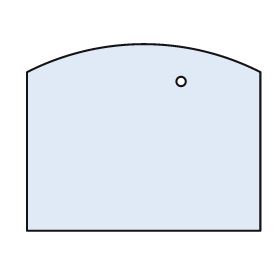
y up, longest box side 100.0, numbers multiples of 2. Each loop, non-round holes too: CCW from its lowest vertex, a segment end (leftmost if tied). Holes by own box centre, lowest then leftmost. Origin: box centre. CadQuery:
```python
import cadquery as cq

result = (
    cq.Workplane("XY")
    .moveTo(-50.0, -40.0)
    .lineTo(50.0, -40.0)
    .lineTo(50.0, 28.0)
    .threePointArc((0.0, 40.0), (-50.0, 28.0))
    .close()
    .moveTo(16.0, 24.0)
    .circle(2.0)
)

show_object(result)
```